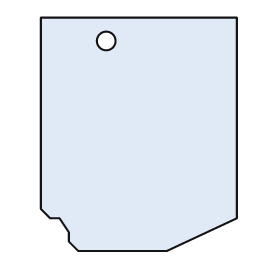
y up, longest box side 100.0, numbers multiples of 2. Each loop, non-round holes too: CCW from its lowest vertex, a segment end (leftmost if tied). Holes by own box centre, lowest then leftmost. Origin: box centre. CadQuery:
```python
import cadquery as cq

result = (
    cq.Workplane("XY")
    .moveTo(-26.0, -50.0)
    .lineTo(12.0, -50.0)
    .lineTo(42.0, -36.0)
    .lineTo(42.0, 50.0)
    .lineTo(-42.0, 50.0)
    .lineTo(-42.0, -32.0)
    .lineTo(-38.0, -36.0)
    .lineTo(-34.0, -36.0)
    .lineTo(-30.0, -42.0)
    .lineTo(-30.0, -46.0)
    .close()
    .moveTo(-14.0, 40.0)
    .circle(4.0)
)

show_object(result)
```